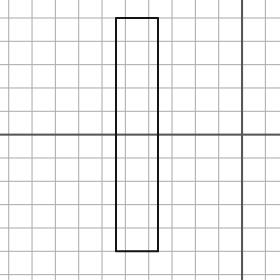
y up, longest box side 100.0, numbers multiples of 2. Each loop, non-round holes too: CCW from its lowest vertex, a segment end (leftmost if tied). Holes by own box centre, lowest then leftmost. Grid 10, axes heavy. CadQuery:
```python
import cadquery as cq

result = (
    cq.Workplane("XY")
    .moveTo(-54.0, -50.0)
    .lineTo(-36.0, -50.0)
    .lineTo(-36.0, 50.0)
    .lineTo(-54.0, 50.0)
    .close()
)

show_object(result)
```